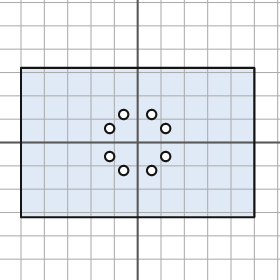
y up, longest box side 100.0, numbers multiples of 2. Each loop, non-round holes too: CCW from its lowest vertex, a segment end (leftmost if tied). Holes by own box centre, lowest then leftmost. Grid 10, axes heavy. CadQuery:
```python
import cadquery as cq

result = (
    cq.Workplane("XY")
    .moveTo(-50.0, -32.0)
    .lineTo(50.0, -32.0)
    .lineTo(50.0, 32.0)
    .lineTo(-50.0, 32.0)
    .close()
    .moveTo(-6.0, -12.0)
    .circle(2.0)
    .moveTo(6.0, -12.0)
    .circle(2.0)
    .moveTo(-12.0, -6.0)
    .circle(2.0)
    .moveTo(12.0, -6.0)
    .circle(2.0)
    .moveTo(-12.0, 6.0)
    .circle(2.0)
    .moveTo(12.0, 6.0)
    .circle(2.0)
    .moveTo(-6.0, 12.0)
    .circle(2.0)
    .moveTo(6.0, 12.0)
    .circle(2.0)
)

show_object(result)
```